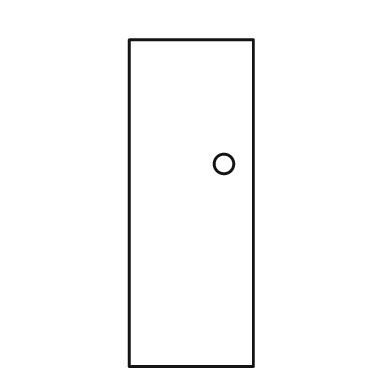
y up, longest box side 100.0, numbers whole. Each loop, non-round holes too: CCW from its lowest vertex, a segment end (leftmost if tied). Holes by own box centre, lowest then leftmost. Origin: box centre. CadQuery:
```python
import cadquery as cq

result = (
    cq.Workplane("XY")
    .moveTo(-19.0, -50.0)
    .lineTo(19.0, -50.0)
    .lineTo(19.0, 50.0)
    .lineTo(-19.0, 50.0)
    .close()
    .moveTo(10.0, 12.0)
    .circle(3.0)
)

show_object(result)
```